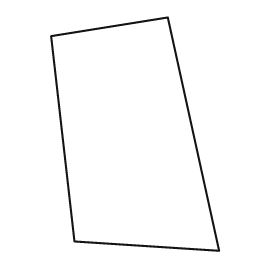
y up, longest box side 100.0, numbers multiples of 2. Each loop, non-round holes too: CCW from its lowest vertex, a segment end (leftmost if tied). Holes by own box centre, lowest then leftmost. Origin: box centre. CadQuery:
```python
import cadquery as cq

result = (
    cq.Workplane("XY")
    .moveTo(36.0, -50.0)
    .lineTo(14.0, 50.0)
    .lineTo(-36.0, 42.0)
    .lineTo(-26.0, -46.0)
    .close()
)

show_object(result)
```